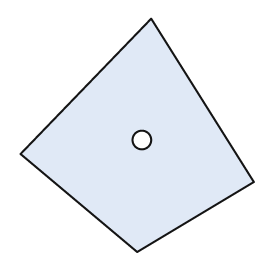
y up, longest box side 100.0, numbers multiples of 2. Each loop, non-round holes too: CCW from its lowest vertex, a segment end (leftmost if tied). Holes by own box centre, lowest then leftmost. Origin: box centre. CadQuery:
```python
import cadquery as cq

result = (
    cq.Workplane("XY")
    .moveTo(0.0, -50.0)
    .lineTo(50.0, -20.0)
    .lineTo(6.0, 50.0)
    .lineTo(-50.0, -8.0)
    .close()
    .moveTo(2.0, -2.0)
    .circle(4.0)
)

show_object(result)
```